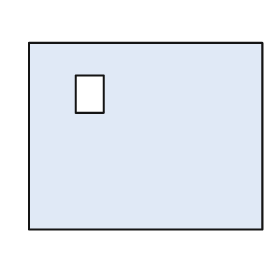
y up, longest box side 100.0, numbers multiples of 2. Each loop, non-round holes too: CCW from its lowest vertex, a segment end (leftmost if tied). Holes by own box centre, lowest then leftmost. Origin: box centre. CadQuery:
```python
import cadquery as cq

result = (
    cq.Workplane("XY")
    .moveTo(-50.0, -40.0)
    .lineTo(50.0, -40.0)
    .lineTo(50.0, 40.0)
    .lineTo(-50.0, 40.0)
    .close()
    .moveTo(-30.0, 10.0)
    .lineTo(-18.0, 10.0)
    .lineTo(-18.0, 26.0)
    .lineTo(-30.0, 26.0)
    .close()
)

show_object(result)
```